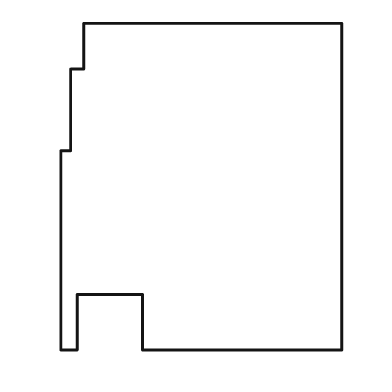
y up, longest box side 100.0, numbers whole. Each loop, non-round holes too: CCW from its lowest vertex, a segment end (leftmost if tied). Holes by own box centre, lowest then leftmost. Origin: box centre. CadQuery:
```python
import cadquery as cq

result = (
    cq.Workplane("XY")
    .moveTo(-43.0, -50.0)
    .lineTo(-38.0, -50.0)
    .lineTo(-38.0, -33.0)
    .lineTo(-18.0, -33.0)
    .lineTo(-18.0, -50.0)
    .lineTo(43.0, -50.0)
    .lineTo(43.0, 50.0)
    .lineTo(-36.0, 50.0)
    .lineTo(-36.0, 36.0)
    .lineTo(-40.0, 36.0)
    .lineTo(-40.0, 11.0)
    .lineTo(-43.0, 11.0)
    .close()
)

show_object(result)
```